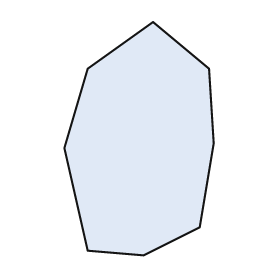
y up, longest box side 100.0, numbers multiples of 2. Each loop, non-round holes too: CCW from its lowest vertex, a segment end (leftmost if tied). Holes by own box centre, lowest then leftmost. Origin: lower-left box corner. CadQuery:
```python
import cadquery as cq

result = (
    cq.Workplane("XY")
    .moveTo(34.0, 0.0)
    .lineTo(58.0, 12.0)
    .lineTo(64.0, 48.0)
    .lineTo(62.0, 80.0)
    .lineTo(38.0, 100.0)
    .lineTo(10.0, 80.0)
    .lineTo(0.0, 46.0)
    .lineTo(10.0, 2.0)
    .close()
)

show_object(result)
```